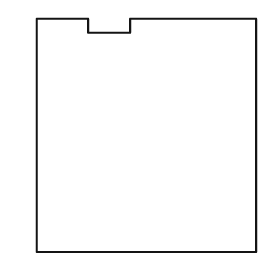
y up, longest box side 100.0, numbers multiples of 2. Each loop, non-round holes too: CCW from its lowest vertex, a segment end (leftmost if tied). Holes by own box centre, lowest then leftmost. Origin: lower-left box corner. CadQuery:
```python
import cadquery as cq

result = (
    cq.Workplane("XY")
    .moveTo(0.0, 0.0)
    .lineTo(94.0, 0.0)
    .lineTo(94.0, 100.0)
    .lineTo(40.0, 100.0)
    .lineTo(40.0, 94.0)
    .lineTo(22.0, 94.0)
    .lineTo(22.0, 100.0)
    .lineTo(0.0, 100.0)
    .close()
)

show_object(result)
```